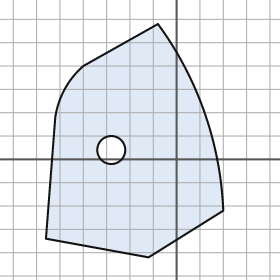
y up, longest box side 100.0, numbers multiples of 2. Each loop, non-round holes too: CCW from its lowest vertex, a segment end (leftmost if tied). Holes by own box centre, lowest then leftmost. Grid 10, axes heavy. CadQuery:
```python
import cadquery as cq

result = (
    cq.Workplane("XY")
    .moveTo(-12.0, -42.0)
    .lineTo(20.0, -22.0)
    .threePointArc((12.0, 20.0), (-8.0, 58.0))
    .lineTo(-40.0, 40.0)
    .threePointArc((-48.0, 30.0), (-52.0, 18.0))
    .lineTo(-56.0, -34.0)
    .close()
    .moveTo(-28.0, 4.0)
    .circle(6.0)
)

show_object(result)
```